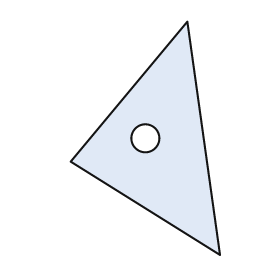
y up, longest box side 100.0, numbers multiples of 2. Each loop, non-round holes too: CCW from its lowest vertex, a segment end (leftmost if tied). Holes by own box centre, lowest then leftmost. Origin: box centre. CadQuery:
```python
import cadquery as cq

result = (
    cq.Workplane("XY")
    .moveTo(32.0, -50.0)
    .lineTo(18.0, 50.0)
    .lineTo(-32.0, -10.0)
    .close()
    .moveTo(0.0, 0.0)
    .circle(6.0)
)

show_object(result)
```